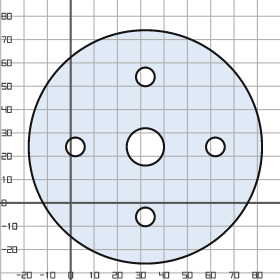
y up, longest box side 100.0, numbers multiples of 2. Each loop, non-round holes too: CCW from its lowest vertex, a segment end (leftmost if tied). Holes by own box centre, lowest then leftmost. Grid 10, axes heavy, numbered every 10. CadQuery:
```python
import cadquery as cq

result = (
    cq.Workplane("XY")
    .moveTo(32.0, 24.0)
    .circle(50.0)
    .moveTo(32.0, -6.0)
    .circle(4.0)
    .moveTo(2.0, 24.0)
    .circle(4.0)
    .moveTo(32.0, 24.0)
    .circle(8.0)
    .moveTo(62.0, 24.0)
    .circle(4.0)
    .moveTo(32.0, 54.0)
    .circle(4.0)
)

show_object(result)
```